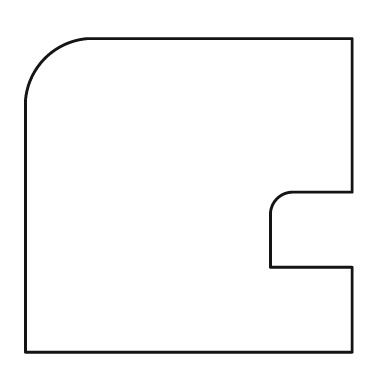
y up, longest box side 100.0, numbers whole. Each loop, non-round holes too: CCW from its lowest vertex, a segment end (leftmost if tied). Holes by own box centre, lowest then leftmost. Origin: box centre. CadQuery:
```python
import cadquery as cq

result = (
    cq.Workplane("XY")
    .moveTo(-50.0, -48.0)
    .lineTo(50.0, -48.0)
    .lineTo(50.0, -22.0)
    .lineTo(25.0, -22.0)
    .lineTo(25.0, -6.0)
    .threePointArc((27.0, -1.0), (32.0, 1.0))
    .lineTo(50.0, 1.0)
    .lineTo(50.0, 48.0)
    .lineTo(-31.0, 48.0)
    .threePointArc((-44.0, 42.0), (-50.0, 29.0))
    .close()
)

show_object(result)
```